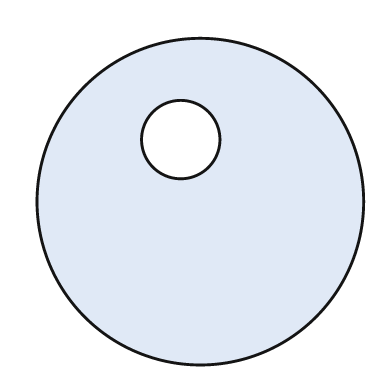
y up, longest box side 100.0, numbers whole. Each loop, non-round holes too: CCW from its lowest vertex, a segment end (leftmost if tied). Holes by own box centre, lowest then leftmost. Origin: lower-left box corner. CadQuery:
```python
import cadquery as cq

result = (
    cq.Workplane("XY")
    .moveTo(50.0, 50.0)
    .circle(50.0)
    .moveTo(44.0, 69.0)
    .circle(12.0)
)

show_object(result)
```